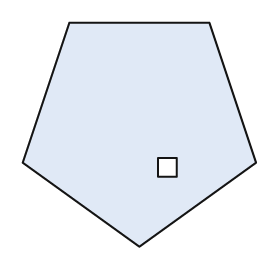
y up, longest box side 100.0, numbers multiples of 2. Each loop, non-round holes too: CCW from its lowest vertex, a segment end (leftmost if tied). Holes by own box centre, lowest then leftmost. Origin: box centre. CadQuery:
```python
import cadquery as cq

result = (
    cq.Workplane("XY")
    .moveTo(0.0, -48.0)
    .lineTo(50.0, -12.0)
    .lineTo(30.0, 48.0)
    .lineTo(-30.0, 48.0)
    .lineTo(-50.0, -12.0)
    .close()
    .moveTo(8.0, -18.0)
    .lineTo(16.0, -18.0)
    .lineTo(16.0, -10.0)
    .lineTo(8.0, -10.0)
    .close()
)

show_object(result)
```